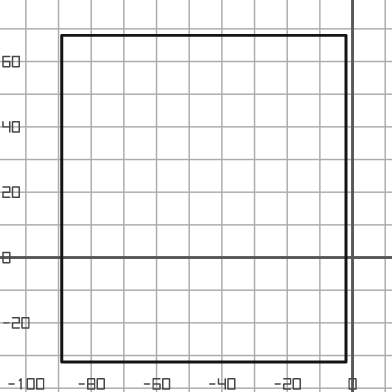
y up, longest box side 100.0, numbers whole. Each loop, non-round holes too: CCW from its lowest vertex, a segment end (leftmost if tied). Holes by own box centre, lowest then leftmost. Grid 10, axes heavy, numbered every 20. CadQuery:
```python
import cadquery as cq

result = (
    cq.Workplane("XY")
    .moveTo(-89.0, -32.0)
    .lineTo(-2.0, -32.0)
    .lineTo(-2.0, 68.0)
    .lineTo(-89.0, 68.0)
    .close()
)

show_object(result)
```